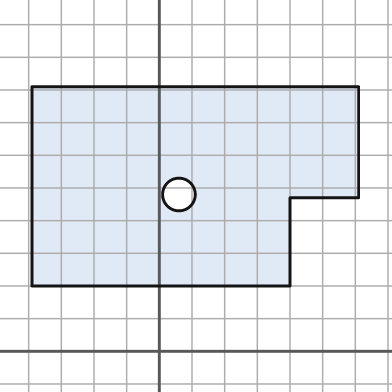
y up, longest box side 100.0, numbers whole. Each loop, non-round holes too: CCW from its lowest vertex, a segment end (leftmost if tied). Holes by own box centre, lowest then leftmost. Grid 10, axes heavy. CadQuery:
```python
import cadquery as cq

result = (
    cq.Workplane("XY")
    .moveTo(-39.0, 20.0)
    .lineTo(40.0, 20.0)
    .lineTo(40.0, 47.0)
    .lineTo(61.0, 47.0)
    .lineTo(61.0, 81.0)
    .lineTo(-39.0, 81.0)
    .close()
    .moveTo(6.0, 48.0)
    .circle(5.0)
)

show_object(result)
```